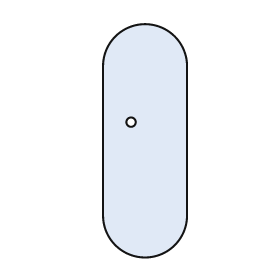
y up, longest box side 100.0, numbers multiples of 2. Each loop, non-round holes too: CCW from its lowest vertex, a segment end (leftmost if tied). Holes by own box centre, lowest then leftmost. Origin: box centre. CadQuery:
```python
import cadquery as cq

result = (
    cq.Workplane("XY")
    .moveTo(-18.0, -32.0)
    .threePointArc((0.0, -50.0), (18.0, -32.0))
    .lineTo(18.0, 32.0)
    .threePointArc((0.0, 50.0), (-18.0, 32.0))
    .close()
    .moveTo(-6.0, 8.0)
    .circle(2.0)
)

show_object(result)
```